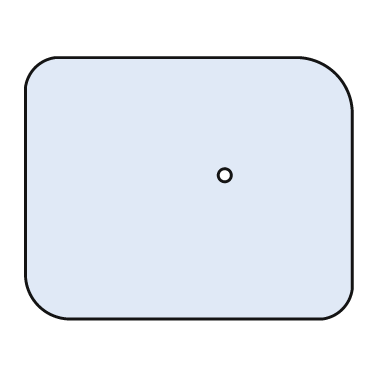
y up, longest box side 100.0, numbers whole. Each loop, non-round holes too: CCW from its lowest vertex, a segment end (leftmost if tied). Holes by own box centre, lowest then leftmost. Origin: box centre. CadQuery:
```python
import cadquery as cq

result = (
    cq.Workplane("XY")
    .moveTo(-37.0, -40.0)
    .lineTo(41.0, -40.0)
    .threePointArc((47.0, -37.0), (50.0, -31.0))
    .lineTo(50.0, 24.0)
    .threePointArc((45.0, 35.0), (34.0, 40.0))
    .lineTo(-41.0, 40.0)
    .threePointArc((-47.0, 37.0), (-50.0, 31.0))
    .lineTo(-50.0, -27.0)
    .threePointArc((-46.0, -36.0), (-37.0, -40.0))
    .close()
    .moveTo(11.0, 4.0)
    .circle(2.0)
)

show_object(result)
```